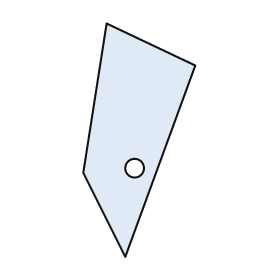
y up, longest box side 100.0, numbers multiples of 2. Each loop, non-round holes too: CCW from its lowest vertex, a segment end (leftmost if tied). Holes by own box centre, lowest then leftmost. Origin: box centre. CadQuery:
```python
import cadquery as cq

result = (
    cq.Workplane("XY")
    .moveTo(-6.0, -50.0)
    .lineTo(24.0, 32.0)
    .lineTo(-14.0, 50.0)
    .lineTo(-24.0, -14.0)
    .close()
    .moveTo(-2.0, -12.0)
    .circle(4.0)
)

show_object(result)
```